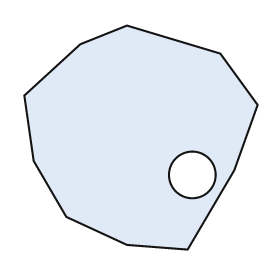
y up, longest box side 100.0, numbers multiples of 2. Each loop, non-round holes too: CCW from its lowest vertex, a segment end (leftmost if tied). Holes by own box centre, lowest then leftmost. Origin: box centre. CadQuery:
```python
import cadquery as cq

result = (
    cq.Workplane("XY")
    .moveTo(20.0, -48.0)
    .lineTo(40.0, -14.0)
    .lineTo(50.0, 14.0)
    .lineTo(34.0, 36.0)
    .lineTo(-6.0, 48.0)
    .lineTo(-26.0, 40.0)
    .lineTo(-50.0, 18.0)
    .lineTo(-46.0, -10.0)
    .lineTo(-32.0, -34.0)
    .lineTo(-6.0, -46.0)
    .close()
    .moveTo(22.0, -16.0)
    .circle(10.0)
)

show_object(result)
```